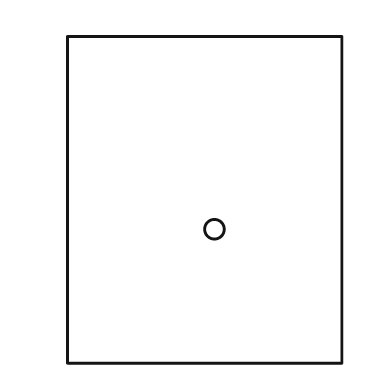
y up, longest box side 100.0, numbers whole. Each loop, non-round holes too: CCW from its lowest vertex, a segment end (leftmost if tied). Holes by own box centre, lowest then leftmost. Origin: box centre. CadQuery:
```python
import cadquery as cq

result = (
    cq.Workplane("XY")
    .moveTo(-42.0, -50.0)
    .lineTo(42.0, -50.0)
    .lineTo(42.0, 50.0)
    .lineTo(-42.0, 50.0)
    .close()
    .moveTo(3.0, -9.0)
    .circle(3.0)
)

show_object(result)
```